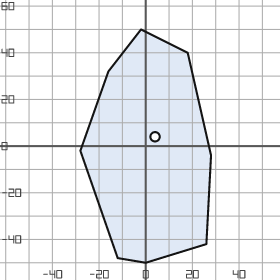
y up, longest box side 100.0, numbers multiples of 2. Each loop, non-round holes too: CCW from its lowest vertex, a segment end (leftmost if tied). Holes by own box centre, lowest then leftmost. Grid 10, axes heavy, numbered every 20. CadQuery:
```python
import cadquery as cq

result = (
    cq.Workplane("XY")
    .moveTo(0.0, -50.0)
    .lineTo(26.0, -42.0)
    .lineTo(28.0, -4.0)
    .lineTo(18.0, 40.0)
    .lineTo(-2.0, 50.0)
    .lineTo(-16.0, 32.0)
    .lineTo(-28.0, -2.0)
    .lineTo(-12.0, -48.0)
    .close()
    .moveTo(4.0, 4.0)
    .circle(2.0)
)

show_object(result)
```